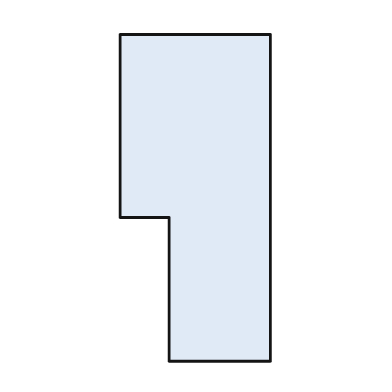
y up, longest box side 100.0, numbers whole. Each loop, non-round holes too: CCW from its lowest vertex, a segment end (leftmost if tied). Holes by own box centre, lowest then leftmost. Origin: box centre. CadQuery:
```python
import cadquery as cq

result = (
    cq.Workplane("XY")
    .moveTo(-8.0, -50.0)
    .lineTo(23.0, -50.0)
    .lineTo(23.0, 50.0)
    .lineTo(-23.0, 50.0)
    .lineTo(-23.0, -6.0)
    .lineTo(-8.0, -6.0)
    .close()
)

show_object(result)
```